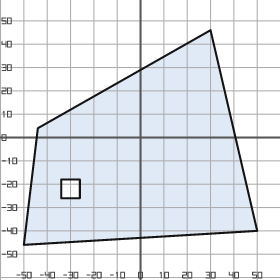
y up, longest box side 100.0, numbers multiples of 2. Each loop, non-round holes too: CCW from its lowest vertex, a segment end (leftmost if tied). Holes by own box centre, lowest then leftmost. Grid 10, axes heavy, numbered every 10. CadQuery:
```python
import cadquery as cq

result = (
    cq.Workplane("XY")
    .moveTo(-50.0, -46.0)
    .lineTo(50.0, -40.0)
    .lineTo(30.0, 46.0)
    .lineTo(-44.0, 4.0)
    .close()
    .moveTo(-34.0, -26.0)
    .lineTo(-26.0, -26.0)
    .lineTo(-26.0, -18.0)
    .lineTo(-34.0, -18.0)
    .close()
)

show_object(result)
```